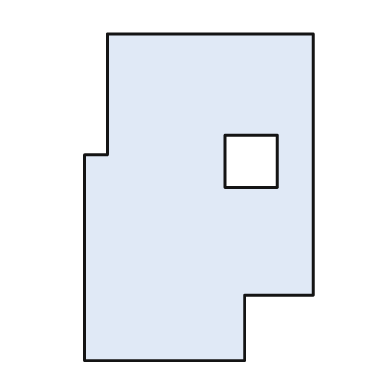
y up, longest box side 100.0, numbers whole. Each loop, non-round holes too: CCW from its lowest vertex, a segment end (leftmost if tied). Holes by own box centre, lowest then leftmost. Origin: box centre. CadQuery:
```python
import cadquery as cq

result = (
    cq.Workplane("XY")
    .moveTo(-35.0, -50.0)
    .lineTo(14.0, -50.0)
    .lineTo(14.0, -30.0)
    .lineTo(35.0, -30.0)
    .lineTo(35.0, 50.0)
    .lineTo(-28.0, 50.0)
    .lineTo(-28.0, 13.0)
    .lineTo(-35.0, 13.0)
    .close()
    .moveTo(8.0, 3.0)
    .lineTo(24.0, 3.0)
    .lineTo(24.0, 19.0)
    .lineTo(8.0, 19.0)
    .close()
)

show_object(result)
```